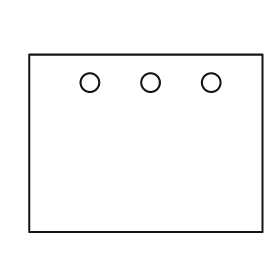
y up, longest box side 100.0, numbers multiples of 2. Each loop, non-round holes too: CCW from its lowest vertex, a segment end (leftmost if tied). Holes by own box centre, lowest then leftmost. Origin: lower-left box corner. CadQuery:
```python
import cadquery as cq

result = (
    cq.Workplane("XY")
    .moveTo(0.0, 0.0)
    .lineTo(100.0, 0.0)
    .lineTo(100.0, 76.0)
    .lineTo(0.0, 76.0)
    .close()
    .moveTo(26.0, 64.0)
    .circle(4.0)
    .moveTo(52.0, 64.0)
    .circle(4.0)
    .moveTo(78.0, 64.0)
    .circle(4.0)
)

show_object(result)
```